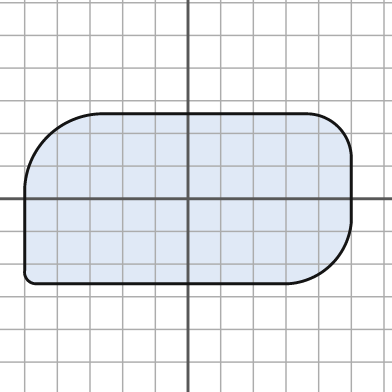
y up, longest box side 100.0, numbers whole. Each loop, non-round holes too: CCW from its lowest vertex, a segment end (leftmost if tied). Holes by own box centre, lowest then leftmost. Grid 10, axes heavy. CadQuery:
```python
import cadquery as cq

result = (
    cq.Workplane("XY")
    .moveTo(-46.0, -26.0)
    .lineTo(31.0, -26.0)
    .threePointArc((44.0, -20.0), (50.0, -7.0))
    .lineTo(50.0, 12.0)
    .threePointArc((46.0, 22.0), (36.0, 26.0))
    .lineTo(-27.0, 26.0)
    .threePointArc((-43.0, 19.0), (-50.0, 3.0))
    .lineTo(-50.0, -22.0)
    .threePointArc((-49.0, -25.0), (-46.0, -26.0))
    .close()
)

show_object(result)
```